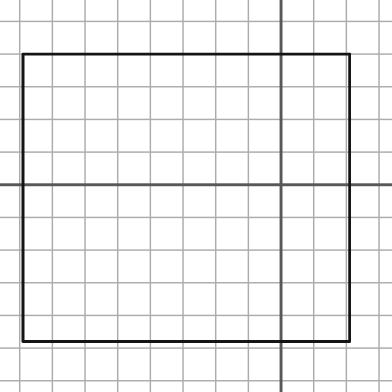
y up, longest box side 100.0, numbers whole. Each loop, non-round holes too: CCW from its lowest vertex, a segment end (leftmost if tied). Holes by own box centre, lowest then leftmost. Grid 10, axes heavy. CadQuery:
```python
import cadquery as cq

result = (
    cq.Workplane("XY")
    .moveTo(-79.0, -48.0)
    .lineTo(21.0, -48.0)
    .lineTo(21.0, 40.0)
    .lineTo(-79.0, 40.0)
    .close()
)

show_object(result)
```